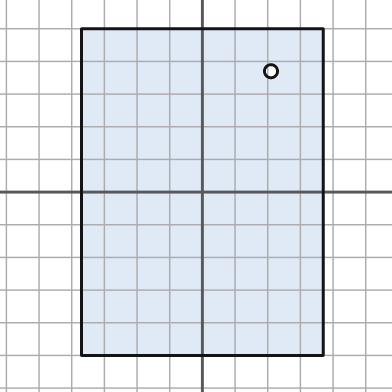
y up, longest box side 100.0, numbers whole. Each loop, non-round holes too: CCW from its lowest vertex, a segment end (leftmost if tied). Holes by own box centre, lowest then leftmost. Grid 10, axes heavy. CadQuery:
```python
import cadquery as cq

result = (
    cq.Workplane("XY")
    .moveTo(-37.0, -50.0)
    .lineTo(37.0, -50.0)
    .lineTo(37.0, 50.0)
    .lineTo(-37.0, 50.0)
    .close()
    .moveTo(21.0, 37.0)
    .circle(2.0)
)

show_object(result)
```